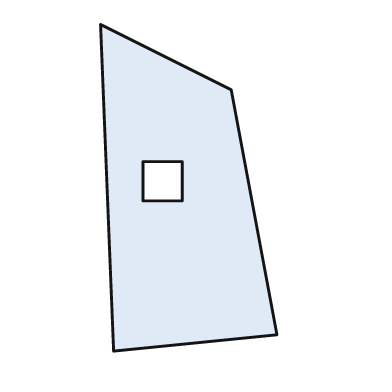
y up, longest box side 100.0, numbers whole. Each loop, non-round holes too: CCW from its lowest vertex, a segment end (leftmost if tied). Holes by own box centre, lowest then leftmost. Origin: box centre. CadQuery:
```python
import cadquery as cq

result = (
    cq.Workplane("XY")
    .moveTo(-23.0, -50.0)
    .lineTo(27.0, -45.0)
    .lineTo(13.0, 30.0)
    .lineTo(-27.0, 50.0)
    .close()
    .moveTo(-14.0, -4.0)
    .lineTo(-2.0, -4.0)
    .lineTo(-2.0, 8.0)
    .lineTo(-14.0, 8.0)
    .close()
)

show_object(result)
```